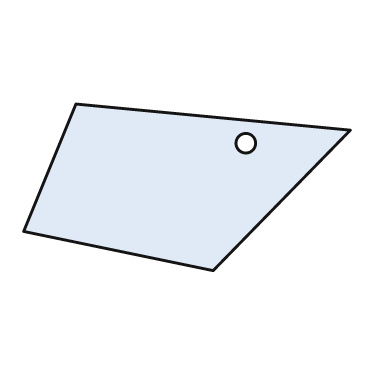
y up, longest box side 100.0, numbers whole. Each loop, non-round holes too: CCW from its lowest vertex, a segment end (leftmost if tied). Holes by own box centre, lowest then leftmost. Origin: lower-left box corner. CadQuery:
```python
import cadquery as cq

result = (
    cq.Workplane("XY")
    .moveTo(58.0, 0.0)
    .lineTo(100.0, 43.0)
    .lineTo(16.0, 51.0)
    .lineTo(0.0, 12.0)
    .close()
    .moveTo(68.0, 39.0)
    .circle(3.0)
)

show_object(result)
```